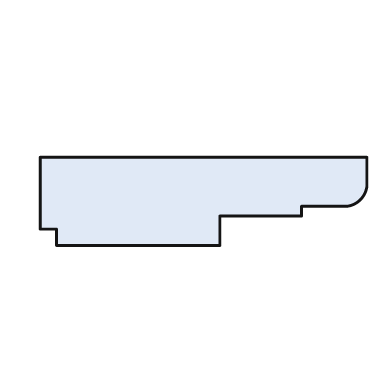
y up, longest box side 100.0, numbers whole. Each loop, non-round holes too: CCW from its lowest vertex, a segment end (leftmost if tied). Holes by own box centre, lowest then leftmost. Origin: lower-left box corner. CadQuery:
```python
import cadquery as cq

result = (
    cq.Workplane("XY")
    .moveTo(5.0, 0.0)
    .lineTo(55.0, 0.0)
    .lineTo(55.0, 9.0)
    .lineTo(80.0, 9.0)
    .lineTo(80.0, 12.0)
    .lineTo(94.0, 12.0)
    .threePointArc((98.0, 14.0), (100.0, 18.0))
    .lineTo(100.0, 27.0)
    .lineTo(0.0, 27.0)
    .lineTo(0.0, 5.0)
    .lineTo(5.0, 5.0)
    .close()
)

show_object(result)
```